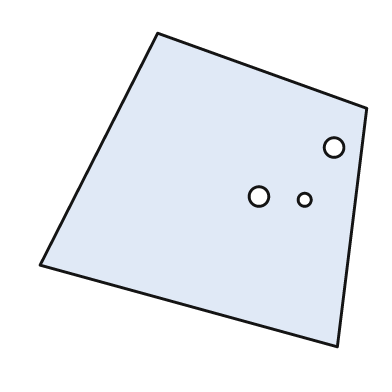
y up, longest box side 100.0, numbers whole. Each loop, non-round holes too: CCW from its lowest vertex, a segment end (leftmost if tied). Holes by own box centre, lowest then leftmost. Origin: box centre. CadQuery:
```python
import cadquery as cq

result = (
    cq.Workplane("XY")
    .moveTo(41.0, -48.0)
    .lineTo(50.0, 25.0)
    .lineTo(-14.0, 48.0)
    .lineTo(-50.0, -23.0)
    .close()
    .moveTo(31.0, -3.0)
    .circle(2.0)
    .moveTo(17.0, -2.0)
    .circle(3.0)
    .moveTo(40.0, 13.0)
    .circle(3.0)
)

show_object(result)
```